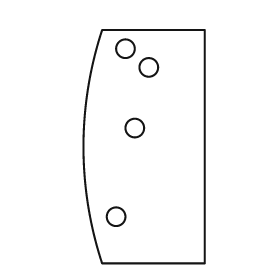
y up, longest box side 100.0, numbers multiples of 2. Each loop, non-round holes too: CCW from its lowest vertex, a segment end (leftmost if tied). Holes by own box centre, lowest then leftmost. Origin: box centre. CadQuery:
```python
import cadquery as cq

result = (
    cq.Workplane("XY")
    .moveTo(-18.0, -50.0)
    .lineTo(26.0, -50.0)
    .lineTo(26.0, 50.0)
    .lineTo(-18.0, 50.0)
    .threePointArc((-26.0, 0.0), (-18.0, -50.0))
    .close()
    .moveTo(-12.0, -30.0)
    .circle(4.0)
    .moveTo(-4.0, 8.0)
    .circle(4.0)
    .moveTo(2.0, 34.0)
    .circle(4.0)
    .moveTo(-8.0, 42.0)
    .circle(4.0)
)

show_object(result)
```